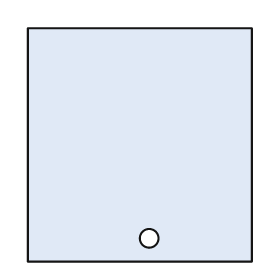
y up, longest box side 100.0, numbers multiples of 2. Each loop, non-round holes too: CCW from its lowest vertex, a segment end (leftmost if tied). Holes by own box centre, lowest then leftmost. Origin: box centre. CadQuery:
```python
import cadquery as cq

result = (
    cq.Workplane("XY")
    .moveTo(-48.0, -50.0)
    .lineTo(48.0, -50.0)
    .lineTo(48.0, 50.0)
    .lineTo(-48.0, 50.0)
    .close()
    .moveTo(4.0, -40.0)
    .circle(4.0)
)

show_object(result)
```